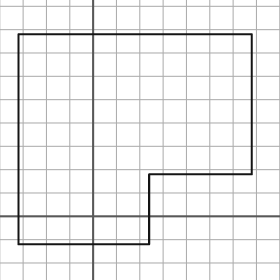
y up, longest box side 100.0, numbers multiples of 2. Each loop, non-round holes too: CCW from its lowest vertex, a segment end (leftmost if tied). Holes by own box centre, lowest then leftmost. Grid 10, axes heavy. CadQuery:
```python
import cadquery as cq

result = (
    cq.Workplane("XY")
    .moveTo(-32.0, -12.0)
    .lineTo(24.0, -12.0)
    .lineTo(24.0, 18.0)
    .lineTo(68.0, 18.0)
    .lineTo(68.0, 78.0)
    .lineTo(-32.0, 78.0)
    .close()
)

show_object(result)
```